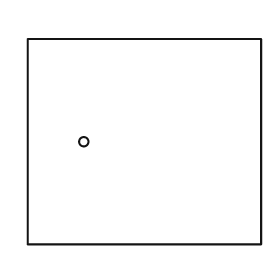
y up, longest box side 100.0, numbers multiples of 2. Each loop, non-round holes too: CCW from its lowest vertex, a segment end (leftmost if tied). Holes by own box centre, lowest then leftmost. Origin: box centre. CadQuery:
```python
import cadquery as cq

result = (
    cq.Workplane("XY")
    .moveTo(-50.0, -44.0)
    .lineTo(50.0, -44.0)
    .lineTo(50.0, 44.0)
    .lineTo(-50.0, 44.0)
    .close()
    .moveTo(-26.0, 0.0)
    .circle(2.0)
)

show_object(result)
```